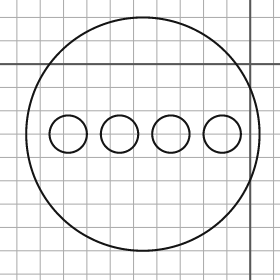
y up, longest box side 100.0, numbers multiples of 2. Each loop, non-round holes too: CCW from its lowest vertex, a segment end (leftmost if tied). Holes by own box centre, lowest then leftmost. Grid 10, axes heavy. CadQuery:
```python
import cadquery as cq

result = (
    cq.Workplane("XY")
    .moveTo(-46.0, -30.0)
    .circle(50.0)
    .moveTo(-78.0, -30.0)
    .circle(8.0)
    .moveTo(-56.0, -30.0)
    .circle(8.0)
    .moveTo(-34.0, -30.0)
    .circle(8.0)
    .moveTo(-12.0, -30.0)
    .circle(8.0)
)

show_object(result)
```